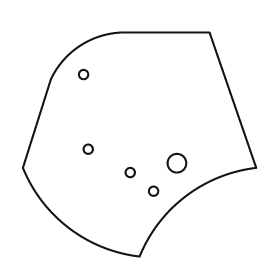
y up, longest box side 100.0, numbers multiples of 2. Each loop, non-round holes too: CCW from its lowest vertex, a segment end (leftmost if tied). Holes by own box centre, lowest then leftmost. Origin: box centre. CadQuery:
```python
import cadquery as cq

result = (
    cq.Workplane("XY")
    .moveTo(0.0, -48.0)
    .threePointArc((20.0, -22.0), (50.0, -10.0))
    .lineTo(30.0, 48.0)
    .lineTo(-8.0, 48.0)
    .threePointArc((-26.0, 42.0), (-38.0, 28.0))
    .lineTo(-50.0, -10.0)
    .threePointArc((-30.0, -36.0), (0.0, -48.0))
    .close()
    .moveTo(6.0, -20.0)
    .circle(2.0)
    .moveTo(-4.0, -12.0)
    .circle(2.0)
    .moveTo(16.0, -8.0)
    .circle(4.0)
    .moveTo(-22.0, -2.0)
    .circle(2.0)
    .moveTo(-24.0, 30.0)
    .circle(2.0)
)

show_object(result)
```